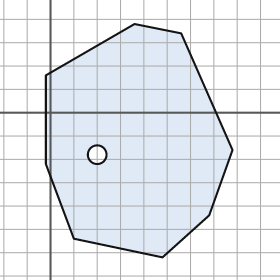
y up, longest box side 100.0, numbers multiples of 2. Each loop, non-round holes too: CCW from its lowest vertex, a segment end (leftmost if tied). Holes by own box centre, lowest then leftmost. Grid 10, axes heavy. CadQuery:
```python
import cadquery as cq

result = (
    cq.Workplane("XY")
    .moveTo(48.0, -62.0)
    .lineTo(68.0, -44.0)
    .lineTo(78.0, -16.0)
    .lineTo(56.0, 34.0)
    .lineTo(36.0, 38.0)
    .lineTo(-2.0, 16.0)
    .lineTo(-2.0, -22.0)
    .lineTo(10.0, -54.0)
    .close()
    .moveTo(20.0, -18.0)
    .circle(4.0)
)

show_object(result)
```